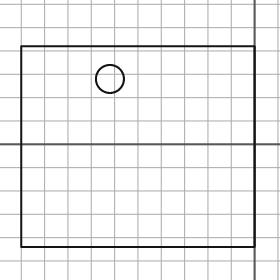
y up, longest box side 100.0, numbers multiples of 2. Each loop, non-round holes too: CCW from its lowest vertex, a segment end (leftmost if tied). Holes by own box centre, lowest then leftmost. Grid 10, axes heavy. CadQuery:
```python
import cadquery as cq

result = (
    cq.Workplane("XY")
    .moveTo(-100.0, -44.0)
    .lineTo(0.0, -44.0)
    .lineTo(0.0, 42.0)
    .lineTo(-100.0, 42.0)
    .close()
    .moveTo(-62.0, 28.0)
    .circle(6.0)
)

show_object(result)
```